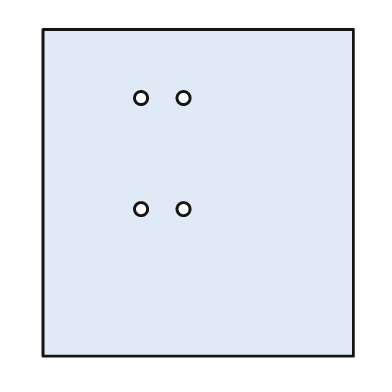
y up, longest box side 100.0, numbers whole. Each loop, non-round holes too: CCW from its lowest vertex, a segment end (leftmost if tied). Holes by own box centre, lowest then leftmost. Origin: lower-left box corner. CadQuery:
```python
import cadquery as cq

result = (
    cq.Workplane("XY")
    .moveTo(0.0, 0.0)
    .lineTo(95.0, 0.0)
    .lineTo(95.0, 100.0)
    .lineTo(0.0, 100.0)
    .close()
    .moveTo(30.0, 45.0)
    .circle(2.0)
    .moveTo(43.0, 45.0)
    .circle(2.0)
    .moveTo(30.0, 79.0)
    .circle(2.0)
    .moveTo(43.0, 79.0)
    .circle(2.0)
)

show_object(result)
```